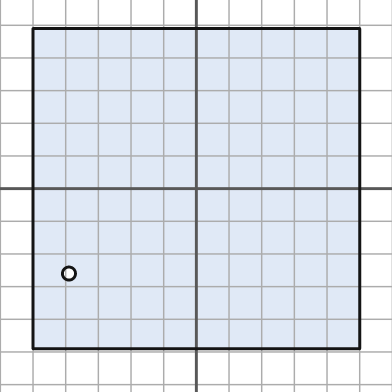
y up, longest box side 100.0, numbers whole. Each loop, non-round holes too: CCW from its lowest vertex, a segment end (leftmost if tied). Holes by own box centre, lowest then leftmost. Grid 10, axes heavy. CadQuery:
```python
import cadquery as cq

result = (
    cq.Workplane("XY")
    .moveTo(-50.0, -49.0)
    .lineTo(50.0, -49.0)
    .lineTo(50.0, 49.0)
    .lineTo(-50.0, 49.0)
    .close()
    .moveTo(-39.0, -26.0)
    .circle(2.0)
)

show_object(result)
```